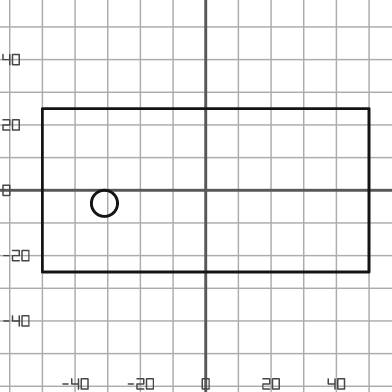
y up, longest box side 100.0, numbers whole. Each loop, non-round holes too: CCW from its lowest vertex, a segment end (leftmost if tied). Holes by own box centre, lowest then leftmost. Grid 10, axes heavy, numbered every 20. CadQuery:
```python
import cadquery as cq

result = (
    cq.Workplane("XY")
    .moveTo(-50.0, -25.0)
    .lineTo(50.0, -25.0)
    .lineTo(50.0, 25.0)
    .lineTo(-50.0, 25.0)
    .close()
    .moveTo(-31.0, -4.0)
    .circle(4.0)
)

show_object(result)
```